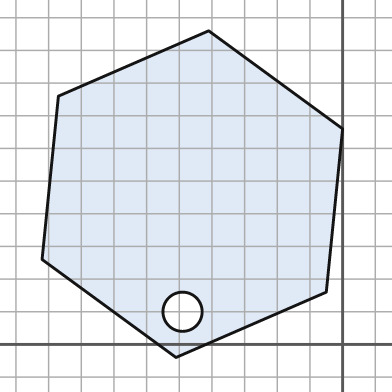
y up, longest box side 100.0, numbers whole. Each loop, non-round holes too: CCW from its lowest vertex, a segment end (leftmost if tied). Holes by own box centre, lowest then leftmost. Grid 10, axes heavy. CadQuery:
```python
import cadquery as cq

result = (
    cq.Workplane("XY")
    .moveTo(-51.0, -4.0)
    .lineTo(-5.0, 16.0)
    .lineTo(0.0, 66.0)
    .lineTo(-41.0, 96.0)
    .lineTo(-87.0, 76.0)
    .lineTo(-92.0, 26.0)
    .close()
    .moveTo(-49.0, 10.0)
    .circle(6.0)
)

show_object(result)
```